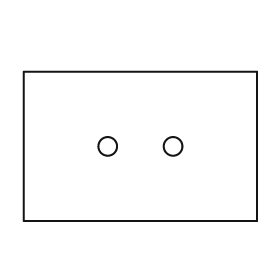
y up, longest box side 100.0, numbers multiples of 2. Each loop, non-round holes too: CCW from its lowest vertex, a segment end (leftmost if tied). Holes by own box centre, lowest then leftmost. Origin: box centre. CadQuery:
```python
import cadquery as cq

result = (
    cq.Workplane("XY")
    .moveTo(-50.0, -32.0)
    .lineTo(50.0, -32.0)
    .lineTo(50.0, 32.0)
    .lineTo(-50.0, 32.0)
    .close()
    .moveTo(-14.0, 0.0)
    .circle(4.0)
    .moveTo(14.0, 0.0)
    .circle(4.0)
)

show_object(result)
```